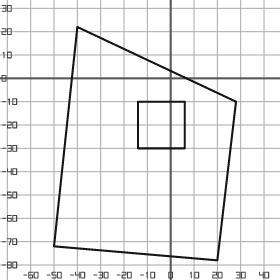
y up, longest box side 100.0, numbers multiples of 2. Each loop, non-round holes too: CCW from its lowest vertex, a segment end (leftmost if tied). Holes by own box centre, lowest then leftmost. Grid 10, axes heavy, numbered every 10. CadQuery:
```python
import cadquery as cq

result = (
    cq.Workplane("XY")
    .moveTo(20.0, -78.0)
    .lineTo(28.0, -10.0)
    .lineTo(-40.0, 22.0)
    .lineTo(-50.0, -72.0)
    .close()
    .moveTo(-14.0, -30.0)
    .lineTo(6.0, -30.0)
    .lineTo(6.0, -10.0)
    .lineTo(-14.0, -10.0)
    .close()
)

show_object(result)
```